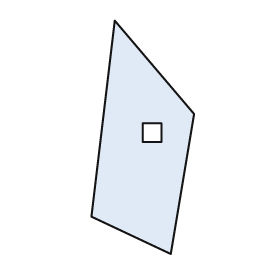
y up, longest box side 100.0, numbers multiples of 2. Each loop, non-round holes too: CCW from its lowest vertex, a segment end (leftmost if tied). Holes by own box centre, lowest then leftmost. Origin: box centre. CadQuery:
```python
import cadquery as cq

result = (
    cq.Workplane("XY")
    .moveTo(12.0, -50.0)
    .lineTo(22.0, 10.0)
    .lineTo(-12.0, 50.0)
    .lineTo(-22.0, -34.0)
    .close()
    .moveTo(0.0, -2.0)
    .lineTo(8.0, -2.0)
    .lineTo(8.0, 6.0)
    .lineTo(0.0, 6.0)
    .close()
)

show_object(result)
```